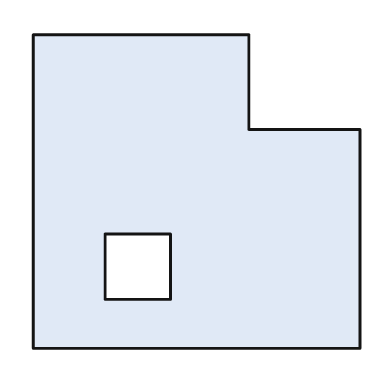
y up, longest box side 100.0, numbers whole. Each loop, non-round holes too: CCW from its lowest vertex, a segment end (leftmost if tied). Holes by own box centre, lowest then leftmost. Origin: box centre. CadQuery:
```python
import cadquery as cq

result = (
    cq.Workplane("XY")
    .moveTo(-50.0, -48.0)
    .lineTo(50.0, -48.0)
    .lineTo(50.0, 19.0)
    .lineTo(16.0, 19.0)
    .lineTo(16.0, 48.0)
    .lineTo(-50.0, 48.0)
    .close()
    .moveTo(-28.0, -33.0)
    .lineTo(-8.0, -33.0)
    .lineTo(-8.0, -13.0)
    .lineTo(-28.0, -13.0)
    .close()
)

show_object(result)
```